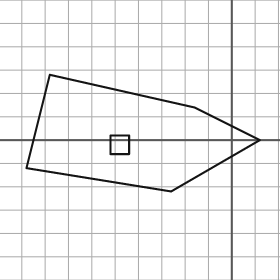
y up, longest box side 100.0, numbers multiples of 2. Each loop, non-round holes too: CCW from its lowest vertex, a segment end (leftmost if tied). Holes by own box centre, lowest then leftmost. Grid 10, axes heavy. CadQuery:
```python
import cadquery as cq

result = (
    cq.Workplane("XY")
    .moveTo(-26.0, -22.0)
    .lineTo(12.0, 0.0)
    .lineTo(-16.0, 14.0)
    .lineTo(-78.0, 28.0)
    .lineTo(-88.0, -12.0)
    .close()
    .moveTo(-52.0, -6.0)
    .lineTo(-44.0, -6.0)
    .lineTo(-44.0, 2.0)
    .lineTo(-52.0, 2.0)
    .close()
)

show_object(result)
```